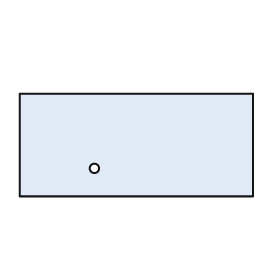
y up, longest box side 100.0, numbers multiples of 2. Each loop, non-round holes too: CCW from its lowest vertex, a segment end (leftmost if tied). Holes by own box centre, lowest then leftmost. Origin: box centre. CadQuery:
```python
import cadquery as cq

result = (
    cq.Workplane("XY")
    .moveTo(-50.0, -22.0)
    .lineTo(50.0, -22.0)
    .lineTo(50.0, 22.0)
    .lineTo(-50.0, 22.0)
    .close()
    .moveTo(-18.0, -10.0)
    .circle(2.0)
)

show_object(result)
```